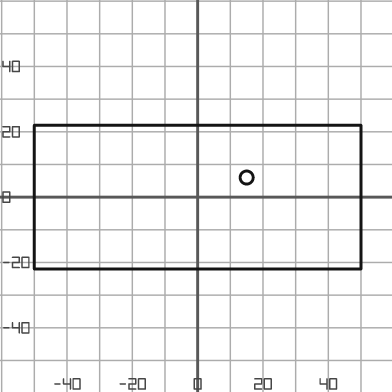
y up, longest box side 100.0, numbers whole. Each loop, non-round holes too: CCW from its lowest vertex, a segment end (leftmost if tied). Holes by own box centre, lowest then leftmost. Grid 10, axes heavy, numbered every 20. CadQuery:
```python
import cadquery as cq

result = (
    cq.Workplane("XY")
    .moveTo(-50.0, -22.0)
    .lineTo(50.0, -22.0)
    .lineTo(50.0, 22.0)
    .lineTo(-50.0, 22.0)
    .close()
    .moveTo(15.0, 6.0)
    .circle(2.0)
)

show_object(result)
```